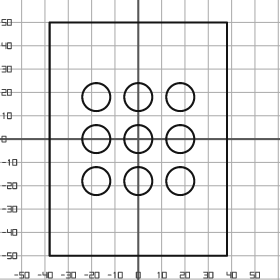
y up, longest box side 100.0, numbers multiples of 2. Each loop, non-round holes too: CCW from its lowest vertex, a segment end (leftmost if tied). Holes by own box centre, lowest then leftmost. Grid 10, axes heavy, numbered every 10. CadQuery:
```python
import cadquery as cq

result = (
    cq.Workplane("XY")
    .moveTo(-38.0, -50.0)
    .lineTo(38.0, -50.0)
    .lineTo(38.0, 50.0)
    .lineTo(-38.0, 50.0)
    .close()
    .moveTo(-18.0, -18.0)
    .circle(6.0)
    .moveTo(0.0, -18.0)
    .circle(6.0)
    .moveTo(18.0, -18.0)
    .circle(6.0)
    .moveTo(-18.0, 0.0)
    .circle(6.0)
    .moveTo(0.0, 0.0)
    .circle(6.0)
    .moveTo(18.0, 0.0)
    .circle(6.0)
    .moveTo(-18.0, 18.0)
    .circle(6.0)
    .moveTo(0.0, 18.0)
    .circle(6.0)
    .moveTo(18.0, 18.0)
    .circle(6.0)
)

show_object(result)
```